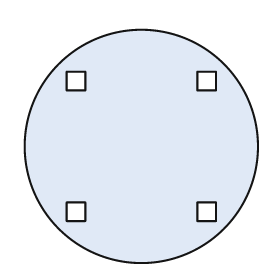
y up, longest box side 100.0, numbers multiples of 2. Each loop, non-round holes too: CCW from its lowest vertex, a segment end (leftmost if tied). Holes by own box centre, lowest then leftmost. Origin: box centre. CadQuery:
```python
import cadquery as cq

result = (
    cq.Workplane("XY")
    .moveTo(0.0, 0.0)
    .circle(50.0)
    .moveTo(-32.0, -32.0)
    .lineTo(-24.0, -32.0)
    .lineTo(-24.0, -24.0)
    .lineTo(-32.0, -24.0)
    .close()
    .moveTo(24.0, -32.0)
    .lineTo(32.0, -32.0)
    .lineTo(32.0, -24.0)
    .lineTo(24.0, -24.0)
    .close()
    .moveTo(-32.0, 24.0)
    .lineTo(-24.0, 24.0)
    .lineTo(-24.0, 32.0)
    .lineTo(-32.0, 32.0)
    .close()
    .moveTo(24.0, 24.0)
    .lineTo(32.0, 24.0)
    .lineTo(32.0, 32.0)
    .lineTo(24.0, 32.0)
    .close()
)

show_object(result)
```